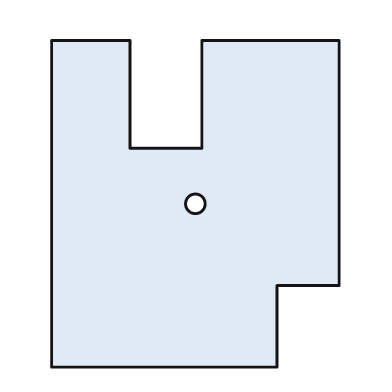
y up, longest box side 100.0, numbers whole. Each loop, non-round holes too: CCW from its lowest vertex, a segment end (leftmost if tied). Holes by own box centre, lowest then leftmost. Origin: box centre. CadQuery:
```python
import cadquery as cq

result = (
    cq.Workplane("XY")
    .moveTo(-44.0, -50.0)
    .lineTo(25.0, -50.0)
    .lineTo(25.0, -25.0)
    .lineTo(44.0, -25.0)
    .lineTo(44.0, 50.0)
    .lineTo(2.0, 50.0)
    .lineTo(2.0, 17.0)
    .lineTo(-20.0, 17.0)
    .lineTo(-20.0, 50.0)
    .lineTo(-44.0, 50.0)
    .close()
    .moveTo(0.0, 0.0)
    .circle(3.0)
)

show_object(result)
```